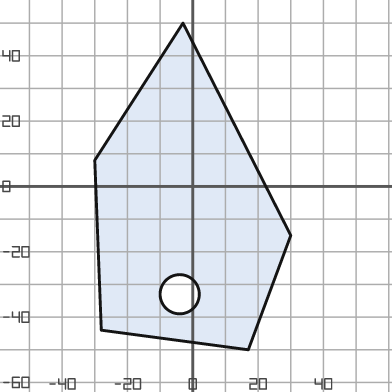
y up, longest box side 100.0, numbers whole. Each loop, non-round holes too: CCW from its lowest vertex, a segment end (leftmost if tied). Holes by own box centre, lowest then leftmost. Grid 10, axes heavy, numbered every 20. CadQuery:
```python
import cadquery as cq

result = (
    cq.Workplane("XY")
    .moveTo(17.0, -50.0)
    .lineTo(30.0, -15.0)
    .lineTo(-3.0, 50.0)
    .lineTo(-30.0, 8.0)
    .lineTo(-28.0, -44.0)
    .close()
    .moveTo(-4.0, -33.0)
    .circle(6.0)
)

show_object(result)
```